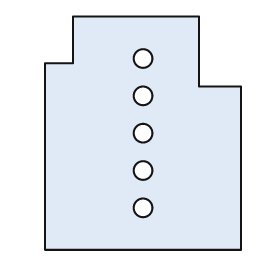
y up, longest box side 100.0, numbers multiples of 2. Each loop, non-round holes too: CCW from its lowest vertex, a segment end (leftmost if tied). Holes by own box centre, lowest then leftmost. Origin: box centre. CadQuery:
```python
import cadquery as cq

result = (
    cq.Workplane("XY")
    .moveTo(-42.0, -50.0)
    .lineTo(42.0, -50.0)
    .lineTo(42.0, 20.0)
    .lineTo(24.0, 20.0)
    .lineTo(24.0, 50.0)
    .lineTo(-30.0, 50.0)
    .lineTo(-30.0, 30.0)
    .lineTo(-42.0, 30.0)
    .close()
    .moveTo(0.0, -32.0)
    .circle(4.0)
    .moveTo(0.0, -16.0)
    .circle(4.0)
    .moveTo(0.0, 0.0)
    .circle(4.0)
    .moveTo(0.0, 16.0)
    .circle(4.0)
    .moveTo(0.0, 32.0)
    .circle(4.0)
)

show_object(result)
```